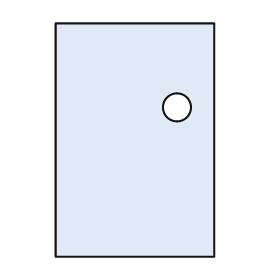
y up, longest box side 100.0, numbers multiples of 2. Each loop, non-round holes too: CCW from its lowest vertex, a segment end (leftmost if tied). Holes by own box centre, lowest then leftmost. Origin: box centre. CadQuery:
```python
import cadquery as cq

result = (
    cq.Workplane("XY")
    .moveTo(-34.0, -50.0)
    .lineTo(34.0, -50.0)
    .lineTo(34.0, 50.0)
    .lineTo(-34.0, 50.0)
    .close()
    .moveTo(18.0, 14.0)
    .circle(6.0)
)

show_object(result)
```